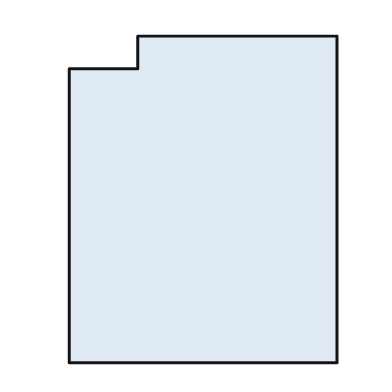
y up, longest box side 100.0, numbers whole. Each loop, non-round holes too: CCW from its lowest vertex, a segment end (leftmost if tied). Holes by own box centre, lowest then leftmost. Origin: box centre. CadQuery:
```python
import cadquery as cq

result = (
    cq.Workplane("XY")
    .moveTo(-41.0, -50.0)
    .lineTo(41.0, -50.0)
    .lineTo(41.0, 50.0)
    .lineTo(-20.0, 50.0)
    .lineTo(-20.0, 40.0)
    .lineTo(-41.0, 40.0)
    .close()
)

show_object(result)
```